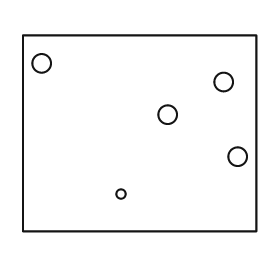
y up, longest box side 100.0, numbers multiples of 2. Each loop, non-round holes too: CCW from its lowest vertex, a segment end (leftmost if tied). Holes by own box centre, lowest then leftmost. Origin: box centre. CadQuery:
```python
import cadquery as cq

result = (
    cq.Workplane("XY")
    .moveTo(-50.0, -42.0)
    .lineTo(50.0, -42.0)
    .lineTo(50.0, 42.0)
    .lineTo(-50.0, 42.0)
    .close()
    .moveTo(-8.0, -26.0)
    .circle(2.0)
    .moveTo(42.0, -10.0)
    .circle(4.0)
    .moveTo(12.0, 8.0)
    .circle(4.0)
    .moveTo(36.0, 22.0)
    .circle(4.0)
    .moveTo(-42.0, 30.0)
    .circle(4.0)
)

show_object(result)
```